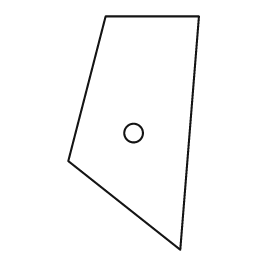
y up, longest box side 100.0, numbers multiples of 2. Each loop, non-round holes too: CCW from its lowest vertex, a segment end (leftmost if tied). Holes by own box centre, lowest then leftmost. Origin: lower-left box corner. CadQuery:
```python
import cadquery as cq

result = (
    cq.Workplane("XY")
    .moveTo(48.0, 0.0)
    .lineTo(56.0, 100.0)
    .lineTo(16.0, 100.0)
    .lineTo(0.0, 38.0)
    .close()
    .moveTo(28.0, 50.0)
    .circle(4.0)
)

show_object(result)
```